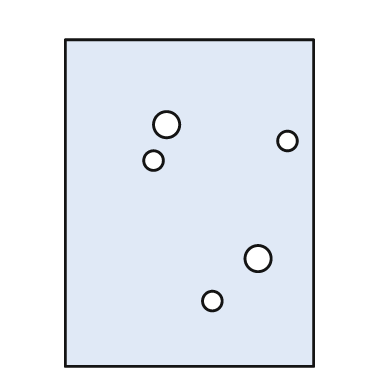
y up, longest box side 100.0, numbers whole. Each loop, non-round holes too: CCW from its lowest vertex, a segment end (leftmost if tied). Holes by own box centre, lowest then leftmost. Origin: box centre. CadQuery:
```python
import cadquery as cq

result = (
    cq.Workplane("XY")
    .moveTo(-38.0, -50.0)
    .lineTo(38.0, -50.0)
    .lineTo(38.0, 50.0)
    .lineTo(-38.0, 50.0)
    .close()
    .moveTo(7.0, -30.0)
    .circle(3.0)
    .moveTo(21.0, -17.0)
    .circle(4.0)
    .moveTo(-11.0, 13.0)
    .circle(3.0)
    .moveTo(30.0, 19.0)
    .circle(3.0)
    .moveTo(-7.0, 24.0)
    .circle(4.0)
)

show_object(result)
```